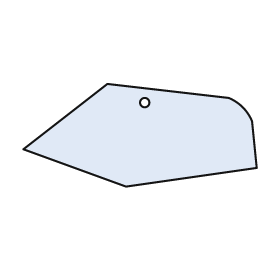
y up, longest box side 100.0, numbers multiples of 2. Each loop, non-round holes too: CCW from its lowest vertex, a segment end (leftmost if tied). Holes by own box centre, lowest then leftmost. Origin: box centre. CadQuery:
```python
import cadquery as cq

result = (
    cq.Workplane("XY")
    .moveTo(-6.0, -22.0)
    .lineTo(50.0, -14.0)
    .lineTo(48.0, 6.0)
    .threePointArc((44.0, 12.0), (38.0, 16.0))
    .lineTo(-14.0, 22.0)
    .lineTo(-50.0, -6.0)
    .close()
    .moveTo(2.0, 14.0)
    .circle(2.0)
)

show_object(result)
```